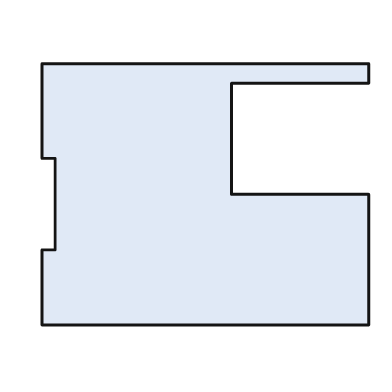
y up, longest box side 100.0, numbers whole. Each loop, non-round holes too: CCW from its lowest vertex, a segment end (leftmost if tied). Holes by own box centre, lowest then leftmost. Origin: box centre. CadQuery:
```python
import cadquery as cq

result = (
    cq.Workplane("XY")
    .moveTo(-50.0, -40.0)
    .lineTo(50.0, -40.0)
    .lineTo(50.0, 0.0)
    .lineTo(8.0, 0.0)
    .lineTo(8.0, 34.0)
    .lineTo(50.0, 34.0)
    .lineTo(50.0, 40.0)
    .lineTo(-50.0, 40.0)
    .lineTo(-50.0, 11.0)
    .lineTo(-46.0, 11.0)
    .lineTo(-46.0, -17.0)
    .lineTo(-50.0, -17.0)
    .close()
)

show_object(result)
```